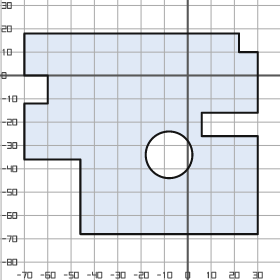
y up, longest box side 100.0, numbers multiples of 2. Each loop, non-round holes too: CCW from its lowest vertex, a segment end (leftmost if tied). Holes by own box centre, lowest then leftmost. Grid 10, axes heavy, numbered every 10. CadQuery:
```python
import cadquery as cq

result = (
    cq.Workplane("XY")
    .moveTo(-46.0, -68.0)
    .lineTo(30.0, -68.0)
    .lineTo(30.0, -26.0)
    .lineTo(6.0, -26.0)
    .lineTo(6.0, -16.0)
    .lineTo(30.0, -16.0)
    .lineTo(30.0, 10.0)
    .lineTo(22.0, 10.0)
    .lineTo(22.0, 18.0)
    .lineTo(-70.0, 18.0)
    .lineTo(-70.0, 0.0)
    .lineTo(-60.0, 0.0)
    .lineTo(-60.0, -12.0)
    .lineTo(-70.0, -12.0)
    .lineTo(-70.0, -36.0)
    .lineTo(-46.0, -36.0)
    .close()
    .moveTo(-8.0, -34.0)
    .circle(10.0)
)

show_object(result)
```